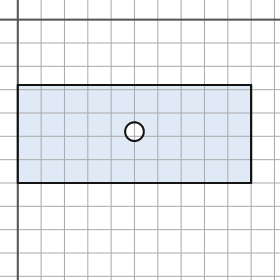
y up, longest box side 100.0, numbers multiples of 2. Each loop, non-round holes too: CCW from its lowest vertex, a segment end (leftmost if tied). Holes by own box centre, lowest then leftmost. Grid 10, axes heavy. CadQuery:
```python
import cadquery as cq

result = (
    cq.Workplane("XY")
    .moveTo(0.0, -70.0)
    .lineTo(100.0, -70.0)
    .lineTo(100.0, -28.0)
    .lineTo(0.0, -28.0)
    .close()
    .moveTo(50.0, -48.0)
    .circle(4.0)
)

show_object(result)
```